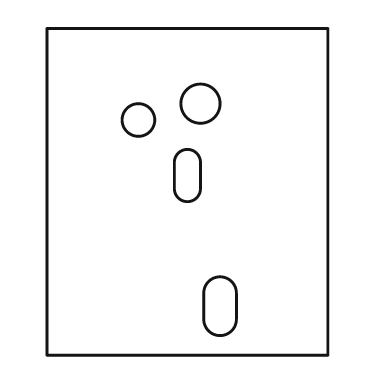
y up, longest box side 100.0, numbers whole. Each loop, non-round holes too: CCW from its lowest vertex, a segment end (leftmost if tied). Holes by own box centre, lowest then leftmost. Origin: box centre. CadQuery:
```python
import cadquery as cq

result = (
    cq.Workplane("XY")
    .moveTo(-43.0, -50.0)
    .lineTo(43.0, -50.0)
    .lineTo(43.0, 50.0)
    .lineTo(-43.0, 50.0)
    .close()
    .moveTo(5.0, -39.0)
    .threePointArc((10.0, -44.0), (15.0, -39.0))
    .lineTo(15.0, -31.0)
    .threePointArc((10.0, -26.0), (5.0, -31.0))
    .close()
    .moveTo(-4.0, 1.0)
    .threePointArc((0.0, -3.0), (4.0, 1.0))
    .lineTo(4.0, 9.0)
    .threePointArc((0.0, 13.0), (-4.0, 9.0))
    .close()
    .moveTo(-15.0, 22.0)
    .circle(5.0)
    .moveTo(4.0, 27.0)
    .circle(6.0)
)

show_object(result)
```